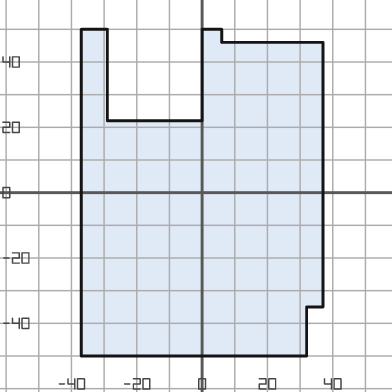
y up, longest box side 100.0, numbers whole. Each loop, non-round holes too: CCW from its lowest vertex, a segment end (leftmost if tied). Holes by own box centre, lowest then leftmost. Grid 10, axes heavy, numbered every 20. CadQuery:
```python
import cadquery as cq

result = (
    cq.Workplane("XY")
    .moveTo(-37.0, -50.0)
    .lineTo(32.0, -50.0)
    .lineTo(32.0, -35.0)
    .lineTo(37.0, -35.0)
    .lineTo(37.0, 46.0)
    .lineTo(6.0, 46.0)
    .lineTo(6.0, 50.0)
    .lineTo(0.0, 50.0)
    .lineTo(0.0, 22.0)
    .lineTo(-29.0, 22.0)
    .lineTo(-29.0, 50.0)
    .lineTo(-37.0, 50.0)
    .close()
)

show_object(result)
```